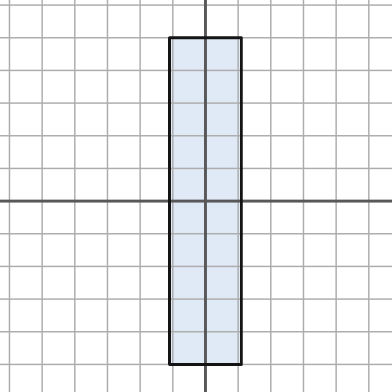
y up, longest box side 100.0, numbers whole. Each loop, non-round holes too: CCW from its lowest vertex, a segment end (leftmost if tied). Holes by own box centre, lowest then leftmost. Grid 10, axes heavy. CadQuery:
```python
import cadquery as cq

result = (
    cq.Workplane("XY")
    .moveTo(-11.0, -50.0)
    .lineTo(11.0, -50.0)
    .lineTo(11.0, 50.0)
    .lineTo(-11.0, 50.0)
    .close()
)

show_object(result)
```